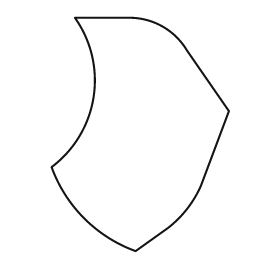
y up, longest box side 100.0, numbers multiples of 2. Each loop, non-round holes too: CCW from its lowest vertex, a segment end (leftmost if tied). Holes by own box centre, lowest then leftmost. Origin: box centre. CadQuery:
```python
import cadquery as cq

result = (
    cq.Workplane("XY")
    .moveTo(-2.0, -50.0)
    .lineTo(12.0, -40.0)
    .threePointArc((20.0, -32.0), (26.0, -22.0))
    .lineTo(38.0, 10.0)
    .lineTo(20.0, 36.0)
    .threePointArc((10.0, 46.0), (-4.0, 50.0))
    .lineTo(-28.0, 50.0)
    .threePointArc((-20.0, 16.0), (-38.0, -14.0))
    .threePointArc((-24.0, -36.0), (-2.0, -50.0))
    .close()
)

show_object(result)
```